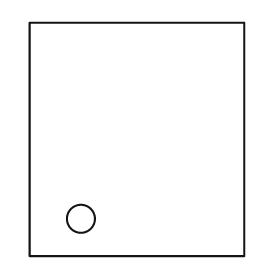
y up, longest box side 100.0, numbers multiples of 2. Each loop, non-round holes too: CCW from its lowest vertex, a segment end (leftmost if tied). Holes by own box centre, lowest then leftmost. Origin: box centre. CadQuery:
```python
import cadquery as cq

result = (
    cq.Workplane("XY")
    .moveTo(-46.0, -50.0)
    .lineTo(46.0, -50.0)
    .lineTo(46.0, 50.0)
    .lineTo(-46.0, 50.0)
    .close()
    .moveTo(-24.0, -34.0)
    .circle(6.0)
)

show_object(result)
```